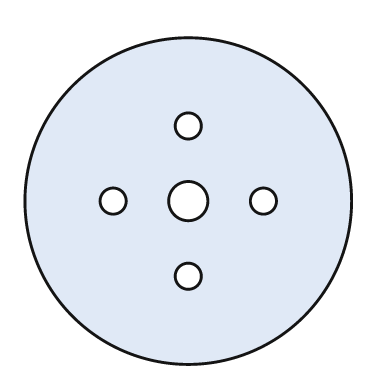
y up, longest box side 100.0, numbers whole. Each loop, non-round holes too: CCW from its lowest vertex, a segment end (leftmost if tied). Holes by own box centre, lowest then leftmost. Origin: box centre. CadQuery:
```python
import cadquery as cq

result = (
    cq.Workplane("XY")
    .moveTo(0.0, 0.0)
    .circle(50.0)
    .moveTo(0.0, -23.0)
    .circle(4.0)
    .moveTo(-23.0, 0.0)
    .circle(4.0)
    .moveTo(0.0, 0.0)
    .circle(6.0)
    .moveTo(23.0, 0.0)
    .circle(4.0)
    .moveTo(0.0, 23.0)
    .circle(4.0)
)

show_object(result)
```